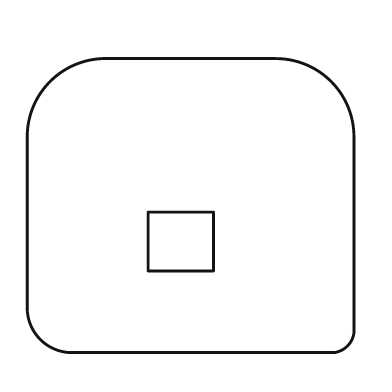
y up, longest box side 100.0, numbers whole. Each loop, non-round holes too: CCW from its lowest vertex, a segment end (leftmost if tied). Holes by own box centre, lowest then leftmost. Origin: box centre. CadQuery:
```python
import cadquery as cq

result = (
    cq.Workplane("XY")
    .moveTo(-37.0, -45.0)
    .lineTo(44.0, -45.0)
    .threePointArc((48.0, -43.0), (50.0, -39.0))
    .lineTo(50.0, 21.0)
    .threePointArc((43.0, 38.0), (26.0, 45.0))
    .lineTo(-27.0, 45.0)
    .threePointArc((-43.0, 38.0), (-50.0, 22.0))
    .lineTo(-50.0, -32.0)
    .threePointArc((-46.0, -41.0), (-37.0, -45.0))
    .close()
    .moveTo(-13.0, -20.0)
    .lineTo(7.0, -20.0)
    .lineTo(7.0, -2.0)
    .lineTo(-13.0, -2.0)
    .close()
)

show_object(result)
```